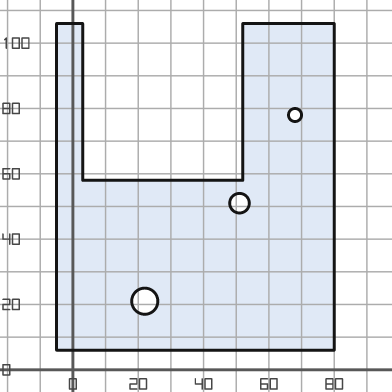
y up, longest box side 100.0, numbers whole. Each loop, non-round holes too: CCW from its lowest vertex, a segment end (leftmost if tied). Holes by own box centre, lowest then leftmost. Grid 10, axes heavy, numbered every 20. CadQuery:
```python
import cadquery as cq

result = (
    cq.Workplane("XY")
    .moveTo(-5.0, 6.0)
    .lineTo(80.0, 6.0)
    .lineTo(80.0, 106.0)
    .lineTo(52.0, 106.0)
    .lineTo(52.0, 58.0)
    .lineTo(3.0, 58.0)
    .lineTo(3.0, 106.0)
    .lineTo(-5.0, 106.0)
    .close()
    .moveTo(22.0, 21.0)
    .circle(4.0)
    .moveTo(51.0, 51.0)
    .circle(3.0)
    .moveTo(68.0, 78.0)
    .circle(2.0)
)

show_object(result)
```